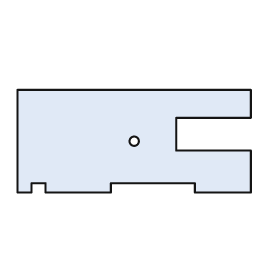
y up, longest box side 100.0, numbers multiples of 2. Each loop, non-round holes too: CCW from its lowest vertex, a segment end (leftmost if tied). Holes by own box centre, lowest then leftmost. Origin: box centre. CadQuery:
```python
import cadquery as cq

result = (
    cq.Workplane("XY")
    .moveTo(-50.0, -22.0)
    .lineTo(-44.0, -22.0)
    .lineTo(-44.0, -18.0)
    .lineTo(-38.0, -18.0)
    .lineTo(-38.0, -22.0)
    .lineTo(-10.0, -22.0)
    .lineTo(-10.0, -18.0)
    .lineTo(26.0, -18.0)
    .lineTo(26.0, -22.0)
    .lineTo(50.0, -22.0)
    .lineTo(50.0, -4.0)
    .lineTo(18.0, -4.0)
    .lineTo(18.0, 10.0)
    .lineTo(50.0, 10.0)
    .lineTo(50.0, 22.0)
    .lineTo(-50.0, 22.0)
    .close()
    .moveTo(0.0, 0.0)
    .circle(2.0)
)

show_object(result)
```